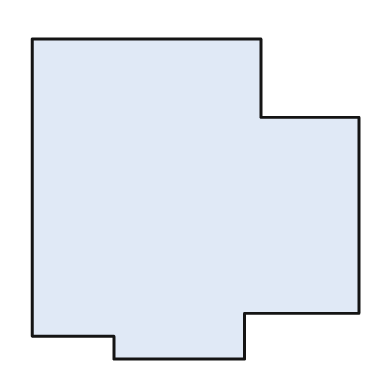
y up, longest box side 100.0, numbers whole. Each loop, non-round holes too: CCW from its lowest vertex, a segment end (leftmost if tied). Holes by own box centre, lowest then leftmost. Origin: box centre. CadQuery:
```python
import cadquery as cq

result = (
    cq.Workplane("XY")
    .moveTo(-25.0, -49.0)
    .lineTo(15.0, -49.0)
    .lineTo(15.0, -35.0)
    .lineTo(50.0, -35.0)
    .lineTo(50.0, 25.0)
    .lineTo(20.0, 25.0)
    .lineTo(20.0, 49.0)
    .lineTo(-50.0, 49.0)
    .lineTo(-50.0, -42.0)
    .lineTo(-25.0, -42.0)
    .close()
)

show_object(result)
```